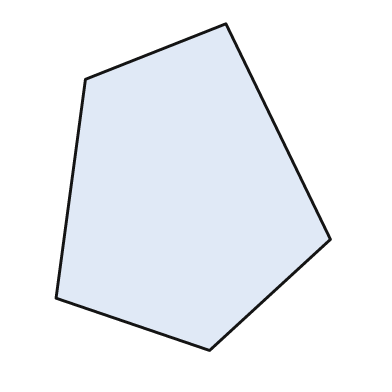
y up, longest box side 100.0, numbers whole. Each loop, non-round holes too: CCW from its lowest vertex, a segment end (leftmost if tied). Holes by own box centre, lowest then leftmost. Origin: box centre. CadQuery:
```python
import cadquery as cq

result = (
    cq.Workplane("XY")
    .moveTo(5.0, -50.0)
    .lineTo(42.0, -16.0)
    .lineTo(10.0, 50.0)
    .lineTo(-33.0, 33.0)
    .lineTo(-42.0, -34.0)
    .close()
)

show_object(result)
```